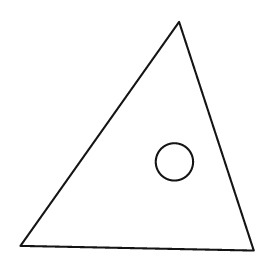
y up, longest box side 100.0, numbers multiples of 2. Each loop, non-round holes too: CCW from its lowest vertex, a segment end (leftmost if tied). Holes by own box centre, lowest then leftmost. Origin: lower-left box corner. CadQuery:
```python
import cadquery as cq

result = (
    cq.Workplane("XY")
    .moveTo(100.0, 0.0)
    .lineTo(68.0, 98.0)
    .lineTo(0.0, 2.0)
    .close()
    .moveTo(66.0, 38.0)
    .circle(8.0)
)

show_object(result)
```